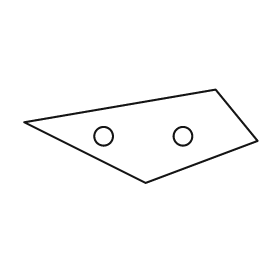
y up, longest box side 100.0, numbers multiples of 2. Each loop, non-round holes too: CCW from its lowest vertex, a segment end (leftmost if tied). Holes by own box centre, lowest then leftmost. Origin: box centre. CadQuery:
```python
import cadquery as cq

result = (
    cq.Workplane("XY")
    .moveTo(2.0, -20.0)
    .lineTo(50.0, -2.0)
    .lineTo(32.0, 20.0)
    .lineTo(-50.0, 6.0)
    .close()
    .moveTo(-16.0, 0.0)
    .circle(4.0)
    .moveTo(18.0, 0.0)
    .circle(4.0)
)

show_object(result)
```